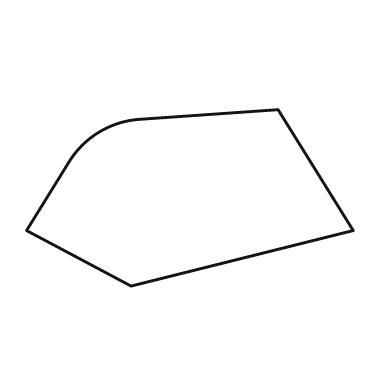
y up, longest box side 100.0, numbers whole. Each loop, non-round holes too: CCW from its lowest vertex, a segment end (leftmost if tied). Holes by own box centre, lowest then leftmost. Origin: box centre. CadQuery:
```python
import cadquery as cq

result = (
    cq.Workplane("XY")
    .moveTo(-18.0, -27.0)
    .lineTo(50.0, -10.0)
    .lineTo(27.0, 27.0)
    .lineTo(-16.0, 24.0)
    .threePointArc((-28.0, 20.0), (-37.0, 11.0))
    .lineTo(-50.0, -10.0)
    .close()
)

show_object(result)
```